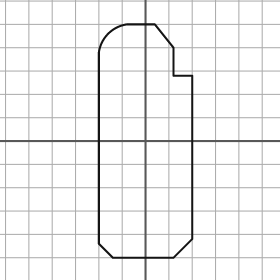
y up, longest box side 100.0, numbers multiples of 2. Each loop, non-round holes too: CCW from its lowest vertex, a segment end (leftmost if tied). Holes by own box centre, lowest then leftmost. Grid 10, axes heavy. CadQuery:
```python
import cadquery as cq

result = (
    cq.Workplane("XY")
    .moveTo(-14.0, -50.0)
    .lineTo(12.0, -50.0)
    .lineTo(20.0, -42.0)
    .lineTo(20.0, 28.0)
    .lineTo(12.0, 28.0)
    .lineTo(12.0, 40.0)
    .lineTo(4.0, 50.0)
    .lineTo(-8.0, 50.0)
    .threePointArc((-16.0, 46.0), (-20.0, 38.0))
    .lineTo(-20.0, -44.0)
    .close()
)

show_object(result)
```